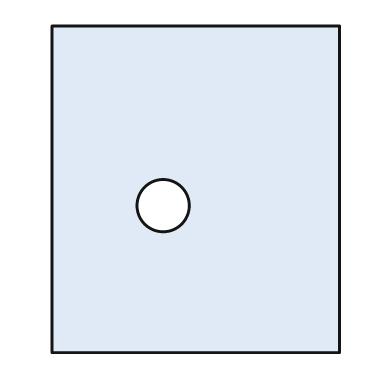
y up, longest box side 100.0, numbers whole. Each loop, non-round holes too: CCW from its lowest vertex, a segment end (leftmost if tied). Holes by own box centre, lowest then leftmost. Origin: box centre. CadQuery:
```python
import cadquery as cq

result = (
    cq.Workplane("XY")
    .moveTo(-44.0, -50.0)
    .lineTo(44.0, -50.0)
    .lineTo(44.0, 50.0)
    .lineTo(-44.0, 50.0)
    .close()
    .moveTo(-10.0, -5.0)
    .circle(8.0)
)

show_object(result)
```